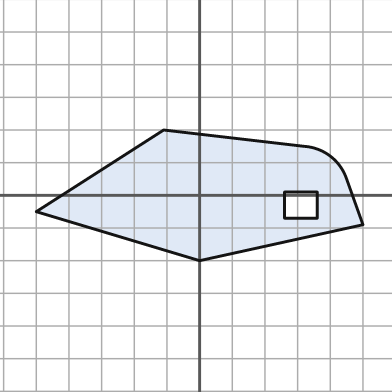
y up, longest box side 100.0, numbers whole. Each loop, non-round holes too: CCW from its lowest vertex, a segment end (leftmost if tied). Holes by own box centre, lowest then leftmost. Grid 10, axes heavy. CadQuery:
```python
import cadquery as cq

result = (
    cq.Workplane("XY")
    .moveTo(0.0, -20.0)
    .lineTo(50.0, -9.0)
    .lineTo(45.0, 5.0)
    .threePointArc((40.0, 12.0), (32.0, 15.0))
    .lineTo(-11.0, 20.0)
    .lineTo(-50.0, -5.0)
    .close()
    .moveTo(26.0, -7.0)
    .lineTo(36.0, -7.0)
    .lineTo(36.0, 1.0)
    .lineTo(26.0, 1.0)
    .close()
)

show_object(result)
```